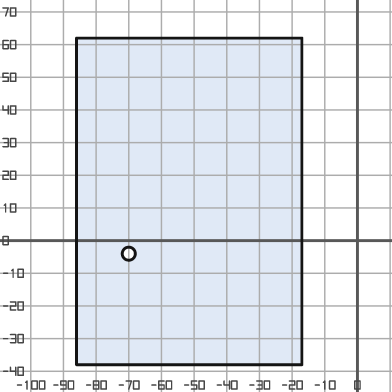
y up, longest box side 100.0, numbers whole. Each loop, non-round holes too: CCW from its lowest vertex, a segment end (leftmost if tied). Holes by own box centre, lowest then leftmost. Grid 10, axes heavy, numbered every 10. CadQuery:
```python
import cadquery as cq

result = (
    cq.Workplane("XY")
    .moveTo(-86.0, -38.0)
    .lineTo(-17.0, -38.0)
    .lineTo(-17.0, 62.0)
    .lineTo(-86.0, 62.0)
    .close()
    .moveTo(-70.0, -4.0)
    .circle(2.0)
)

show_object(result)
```